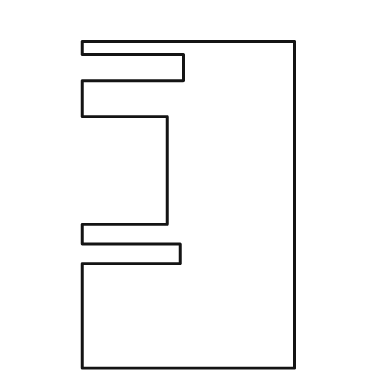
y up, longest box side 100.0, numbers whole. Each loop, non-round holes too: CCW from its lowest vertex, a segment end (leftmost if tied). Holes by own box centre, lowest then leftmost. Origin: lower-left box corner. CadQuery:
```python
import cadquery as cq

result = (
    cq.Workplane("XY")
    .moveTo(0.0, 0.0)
    .lineTo(65.0, 0.0)
    .lineTo(65.0, 100.0)
    .lineTo(0.0, 100.0)
    .lineTo(0.0, 96.0)
    .lineTo(31.0, 96.0)
    .lineTo(31.0, 88.0)
    .lineTo(0.0, 88.0)
    .lineTo(0.0, 77.0)
    .lineTo(26.0, 77.0)
    .lineTo(26.0, 44.0)
    .lineTo(0.0, 44.0)
    .lineTo(0.0, 38.0)
    .lineTo(30.0, 38.0)
    .lineTo(30.0, 32.0)
    .lineTo(0.0, 32.0)
    .close()
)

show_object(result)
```